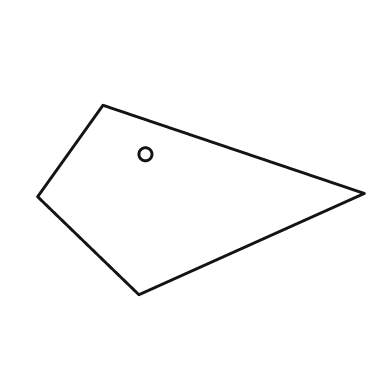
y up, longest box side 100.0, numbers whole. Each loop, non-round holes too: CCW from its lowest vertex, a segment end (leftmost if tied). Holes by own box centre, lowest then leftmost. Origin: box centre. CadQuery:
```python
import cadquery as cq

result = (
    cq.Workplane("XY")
    .moveTo(-19.0, -29.0)
    .lineTo(50.0, 2.0)
    .lineTo(-30.0, 29.0)
    .lineTo(-50.0, 1.0)
    .close()
    .moveTo(-17.0, 14.0)
    .circle(2.0)
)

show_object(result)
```